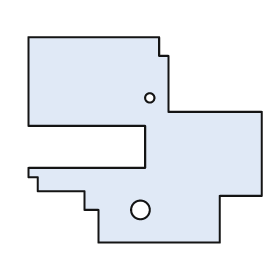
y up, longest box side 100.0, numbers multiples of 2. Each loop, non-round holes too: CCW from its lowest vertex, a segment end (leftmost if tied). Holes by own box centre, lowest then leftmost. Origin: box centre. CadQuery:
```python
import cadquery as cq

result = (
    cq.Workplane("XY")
    .moveTo(-20.0, -44.0)
    .lineTo(32.0, -44.0)
    .lineTo(32.0, -24.0)
    .lineTo(50.0, -24.0)
    .lineTo(50.0, 12.0)
    .lineTo(10.0, 12.0)
    .lineTo(10.0, 36.0)
    .lineTo(6.0, 36.0)
    .lineTo(6.0, 44.0)
    .lineTo(-50.0, 44.0)
    .lineTo(-50.0, 6.0)
    .lineTo(0.0, 6.0)
    .lineTo(0.0, -12.0)
    .lineTo(-50.0, -12.0)
    .lineTo(-50.0, -16.0)
    .lineTo(-46.0, -16.0)
    .lineTo(-46.0, -22.0)
    .lineTo(-26.0, -22.0)
    .lineTo(-26.0, -30.0)
    .lineTo(-20.0, -30.0)
    .close()
    .moveTo(-2.0, -30.0)
    .circle(4.0)
    .moveTo(2.0, 18.0)
    .circle(2.0)
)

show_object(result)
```